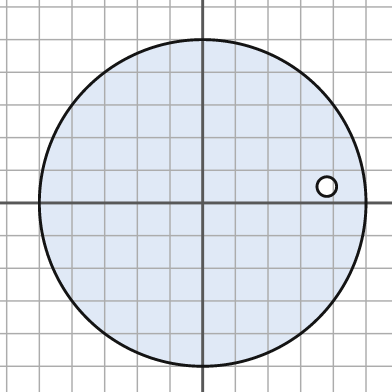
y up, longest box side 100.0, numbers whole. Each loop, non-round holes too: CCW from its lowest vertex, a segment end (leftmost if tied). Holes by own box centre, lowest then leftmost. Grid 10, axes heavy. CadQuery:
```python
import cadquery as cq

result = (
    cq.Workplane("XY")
    .moveTo(0.0, 0.0)
    .circle(50.0)
    .moveTo(38.0, 5.0)
    .circle(3.0)
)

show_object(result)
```